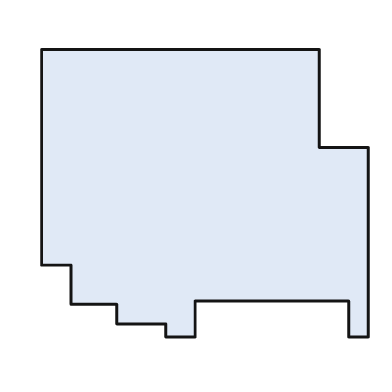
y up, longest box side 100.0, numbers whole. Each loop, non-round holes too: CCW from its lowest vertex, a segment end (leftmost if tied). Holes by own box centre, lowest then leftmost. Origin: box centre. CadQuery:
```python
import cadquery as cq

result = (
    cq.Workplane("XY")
    .moveTo(-12.0, -44.0)
    .lineTo(-3.0, -44.0)
    .lineTo(-3.0, -33.0)
    .lineTo(44.0, -33.0)
    .lineTo(44.0, -44.0)
    .lineTo(50.0, -44.0)
    .lineTo(50.0, 14.0)
    .lineTo(35.0, 14.0)
    .lineTo(35.0, 44.0)
    .lineTo(-50.0, 44.0)
    .lineTo(-50.0, -22.0)
    .lineTo(-41.0, -22.0)
    .lineTo(-41.0, -34.0)
    .lineTo(-27.0, -34.0)
    .lineTo(-27.0, -40.0)
    .lineTo(-12.0, -40.0)
    .close()
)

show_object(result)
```